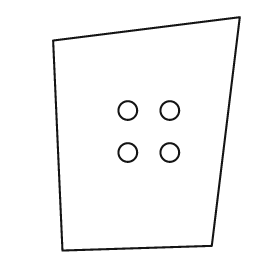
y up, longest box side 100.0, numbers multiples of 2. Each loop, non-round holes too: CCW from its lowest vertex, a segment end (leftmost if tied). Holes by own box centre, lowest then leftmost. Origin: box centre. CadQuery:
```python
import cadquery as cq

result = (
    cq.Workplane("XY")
    .moveTo(-36.0, -50.0)
    .lineTo(28.0, -48.0)
    .lineTo(40.0, 50.0)
    .lineTo(-40.0, 40.0)
    .close()
    .moveTo(-8.0, -8.0)
    .circle(4.0)
    .moveTo(10.0, -8.0)
    .circle(4.0)
    .moveTo(-8.0, 10.0)
    .circle(4.0)
    .moveTo(10.0, 10.0)
    .circle(4.0)
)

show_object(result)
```